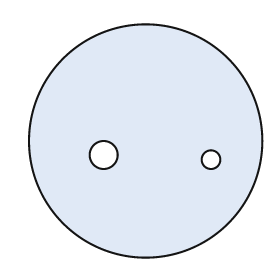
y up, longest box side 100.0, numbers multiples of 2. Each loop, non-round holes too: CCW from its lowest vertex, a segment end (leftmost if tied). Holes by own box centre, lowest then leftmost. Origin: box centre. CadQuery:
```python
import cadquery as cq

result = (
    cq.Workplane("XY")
    .moveTo(0.0, 0.0)
    .circle(50.0)
    .moveTo(28.0, -8.0)
    .circle(4.0)
    .moveTo(-18.0, -6.0)
    .circle(6.0)
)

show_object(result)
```